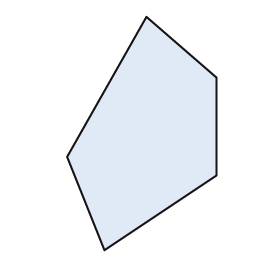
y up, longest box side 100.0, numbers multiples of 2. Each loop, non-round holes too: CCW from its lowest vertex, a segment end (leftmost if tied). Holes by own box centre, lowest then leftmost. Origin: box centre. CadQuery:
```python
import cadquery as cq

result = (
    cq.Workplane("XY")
    .moveTo(-16.0, -50.0)
    .lineTo(32.0, -18.0)
    .lineTo(32.0, 24.0)
    .lineTo(2.0, 50.0)
    .lineTo(-32.0, -10.0)
    .close()
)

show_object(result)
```